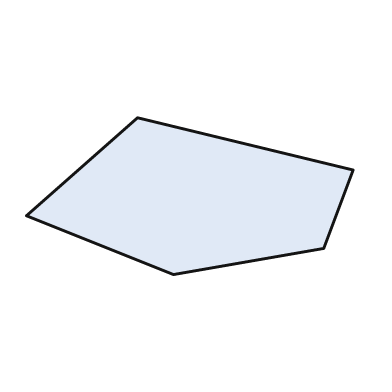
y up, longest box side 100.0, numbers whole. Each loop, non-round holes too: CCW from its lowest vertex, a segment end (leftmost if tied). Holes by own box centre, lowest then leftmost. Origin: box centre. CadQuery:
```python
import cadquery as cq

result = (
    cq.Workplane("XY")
    .moveTo(-5.0, -24.0)
    .lineTo(41.0, -16.0)
    .lineTo(50.0, 8.0)
    .lineTo(-16.0, 24.0)
    .lineTo(-50.0, -6.0)
    .close()
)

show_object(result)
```